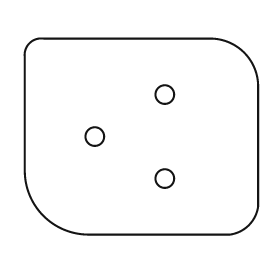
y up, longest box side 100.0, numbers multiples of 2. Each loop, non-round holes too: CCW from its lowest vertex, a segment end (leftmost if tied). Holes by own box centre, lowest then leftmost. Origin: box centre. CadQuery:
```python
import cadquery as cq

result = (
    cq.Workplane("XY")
    .moveTo(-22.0, -42.0)
    .lineTo(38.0, -42.0)
    .threePointArc((46.0, -38.0), (50.0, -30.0))
    .lineTo(50.0, 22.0)
    .threePointArc((44.0, 36.0), (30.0, 42.0))
    .lineTo(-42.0, 42.0)
    .threePointArc((-48.0, 40.0), (-50.0, 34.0))
    .lineTo(-50.0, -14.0)
    .threePointArc((-42.0, -34.0), (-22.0, -42.0))
    .close()
    .moveTo(10.0, -18.0)
    .circle(4.0)
    .moveTo(-20.0, 0.0)
    .circle(4.0)
    .moveTo(10.0, 18.0)
    .circle(4.0)
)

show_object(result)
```